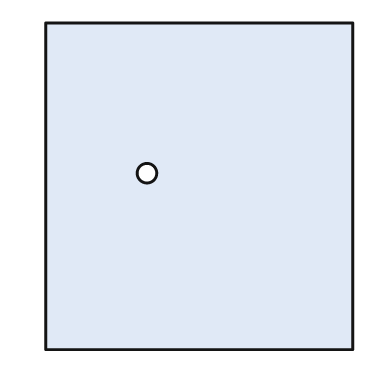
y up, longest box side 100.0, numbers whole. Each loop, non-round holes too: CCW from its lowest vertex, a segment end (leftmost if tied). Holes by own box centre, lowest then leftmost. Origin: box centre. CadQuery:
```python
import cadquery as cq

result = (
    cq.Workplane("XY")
    .moveTo(-47.0, -50.0)
    .lineTo(47.0, -50.0)
    .lineTo(47.0, 50.0)
    .lineTo(-47.0, 50.0)
    .close()
    .moveTo(-16.0, 4.0)
    .circle(3.0)
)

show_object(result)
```